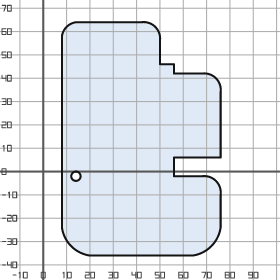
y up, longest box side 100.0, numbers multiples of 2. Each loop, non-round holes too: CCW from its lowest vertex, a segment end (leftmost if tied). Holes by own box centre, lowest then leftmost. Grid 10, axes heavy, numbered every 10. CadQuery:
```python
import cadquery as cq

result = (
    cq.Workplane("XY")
    .moveTo(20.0, -36.0)
    .lineTo(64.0, -36.0)
    .threePointArc((72.0, -32.0), (76.0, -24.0))
    .lineTo(76.0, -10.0)
    .threePointArc((74.0, -4.0), (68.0, -2.0))
    .lineTo(56.0, -2.0)
    .lineTo(56.0, 6.0)
    .lineTo(76.0, 6.0)
    .lineTo(76.0, 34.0)
    .threePointArc((74.0, 40.0), (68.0, 42.0))
    .lineTo(56.0, 42.0)
    .lineTo(56.0, 46.0)
    .lineTo(50.0, 46.0)
    .lineTo(50.0, 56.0)
    .threePointArc((48.0, 62.0), (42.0, 64.0))
    .lineTo(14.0, 64.0)
    .threePointArc((10.0, 62.0), (8.0, 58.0))
    .lineTo(8.0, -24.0)
    .threePointArc((12.0, -32.0), (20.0, -36.0))
    .close()
    .moveTo(14.0, -2.0)
    .circle(2.0)
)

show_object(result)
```